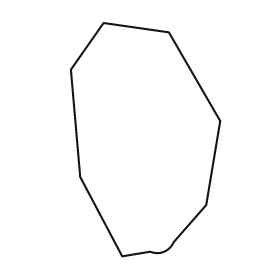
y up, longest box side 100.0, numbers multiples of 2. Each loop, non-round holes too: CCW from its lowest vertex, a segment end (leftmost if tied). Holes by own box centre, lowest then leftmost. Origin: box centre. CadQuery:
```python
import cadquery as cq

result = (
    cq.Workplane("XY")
    .moveTo(-10.0, -50.0)
    .lineTo(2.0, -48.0)
    .threePointArc((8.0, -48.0), (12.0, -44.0))
    .lineTo(26.0, -28.0)
    .lineTo(32.0, 8.0)
    .lineTo(10.0, 46.0)
    .lineTo(-18.0, 50.0)
    .lineTo(-32.0, 30.0)
    .lineTo(-28.0, -16.0)
    .close()
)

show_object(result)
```